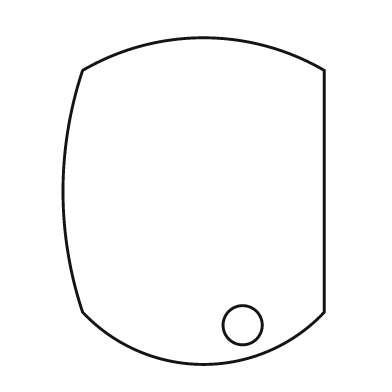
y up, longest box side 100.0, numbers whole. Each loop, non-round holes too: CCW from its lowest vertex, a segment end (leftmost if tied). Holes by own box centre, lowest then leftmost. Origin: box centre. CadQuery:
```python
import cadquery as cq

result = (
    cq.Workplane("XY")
    .moveTo(-34.0, -34.0)
    .threePointArc((3.0, -50.0), (40.0, -34.0))
    .lineTo(40.0, 40.0)
    .threePointArc((3.0, 50.0), (-34.0, 40.0))
    .threePointArc((-40.0, 3.0), (-34.0, -34.0))
    .close()
    .moveTo(15.0, -38.0)
    .circle(6.0)
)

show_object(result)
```